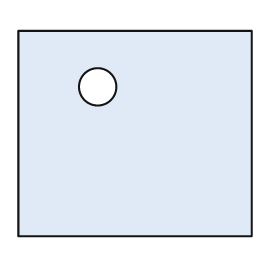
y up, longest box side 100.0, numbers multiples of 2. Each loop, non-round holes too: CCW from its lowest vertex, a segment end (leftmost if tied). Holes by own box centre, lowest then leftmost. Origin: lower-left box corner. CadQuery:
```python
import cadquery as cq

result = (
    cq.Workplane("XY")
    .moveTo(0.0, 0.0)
    .lineTo(100.0, 0.0)
    .lineTo(100.0, 88.0)
    .lineTo(0.0, 88.0)
    .close()
    .moveTo(34.0, 64.0)
    .circle(8.0)
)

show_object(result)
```